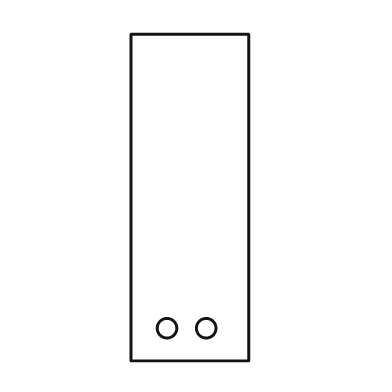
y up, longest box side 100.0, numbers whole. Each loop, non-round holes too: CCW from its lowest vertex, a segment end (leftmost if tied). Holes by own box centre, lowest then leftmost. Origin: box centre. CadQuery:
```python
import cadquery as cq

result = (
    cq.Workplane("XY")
    .moveTo(-18.0, -50.0)
    .lineTo(18.0, -50.0)
    .lineTo(18.0, 50.0)
    .lineTo(-18.0, 50.0)
    .close()
    .moveTo(-7.0, -40.0)
    .circle(3.0)
    .moveTo(5.0, -40.0)
    .circle(3.0)
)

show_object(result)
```